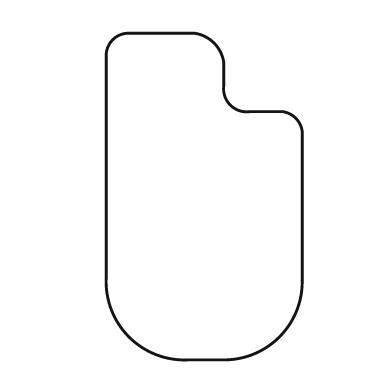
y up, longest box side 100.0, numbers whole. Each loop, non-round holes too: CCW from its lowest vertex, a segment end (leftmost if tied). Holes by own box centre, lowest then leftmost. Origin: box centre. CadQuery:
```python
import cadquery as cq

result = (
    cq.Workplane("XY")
    .moveTo(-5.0, -50.0)
    .lineTo(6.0, -50.0)
    .threePointArc((23.0, -43.0), (30.0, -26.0))
    .lineTo(30.0, 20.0)
    .threePointArc((28.0, 24.0), (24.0, 26.0))
    .lineTo(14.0, 26.0)
    .threePointArc((8.0, 28.0), (6.0, 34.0))
    .lineTo(6.0, 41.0)
    .threePointArc((3.0, 47.0), (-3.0, 50.0))
    .lineTo(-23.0, 50.0)
    .threePointArc((-28.0, 48.0), (-30.0, 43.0))
    .lineTo(-30.0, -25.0)
    .threePointArc((-23.0, -43.0), (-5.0, -50.0))
    .close()
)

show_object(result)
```